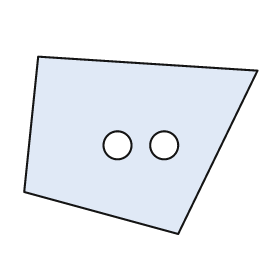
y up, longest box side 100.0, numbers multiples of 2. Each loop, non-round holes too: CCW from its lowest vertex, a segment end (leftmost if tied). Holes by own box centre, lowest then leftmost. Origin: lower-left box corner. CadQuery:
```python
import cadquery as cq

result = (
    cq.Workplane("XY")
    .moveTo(66.0, 0.0)
    .lineTo(100.0, 70.0)
    .lineTo(6.0, 76.0)
    .lineTo(0.0, 18.0)
    .close()
    .moveTo(40.0, 38.0)
    .circle(6.0)
    .moveTo(60.0, 38.0)
    .circle(6.0)
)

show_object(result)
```